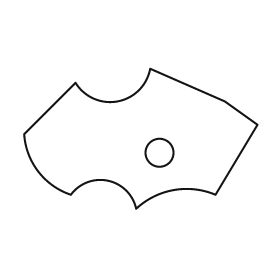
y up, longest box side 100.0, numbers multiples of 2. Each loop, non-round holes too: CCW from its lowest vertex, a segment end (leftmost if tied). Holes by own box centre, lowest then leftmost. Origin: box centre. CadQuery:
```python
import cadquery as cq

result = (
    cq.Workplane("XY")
    .moveTo(-2.0, -30.0)
    .threePointArc((14.0, -22.0), (32.0, -24.0))
    .lineTo(50.0, 6.0)
    .lineTo(36.0, 16.0)
    .lineTo(4.0, 30.0)
    .threePointArc((-10.0, 16.0), (-28.0, 24.0))
    .lineTo(-50.0, 2.0)
    .threePointArc((-44.0, -14.0), (-30.0, -24.0))
    .threePointArc((-14.0, -18.0), (-2.0, -30.0))
    .close()
    .moveTo(8.0, -6.0)
    .circle(6.0)
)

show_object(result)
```